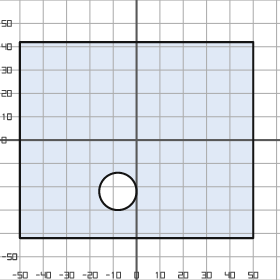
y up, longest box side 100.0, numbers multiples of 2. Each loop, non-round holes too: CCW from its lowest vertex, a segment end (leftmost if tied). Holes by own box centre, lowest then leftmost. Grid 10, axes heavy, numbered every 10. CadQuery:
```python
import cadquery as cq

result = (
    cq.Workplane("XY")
    .moveTo(-50.0, -42.0)
    .lineTo(50.0, -42.0)
    .lineTo(50.0, 42.0)
    .lineTo(-50.0, 42.0)
    .close()
    .moveTo(-8.0, -22.0)
    .circle(8.0)
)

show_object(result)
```